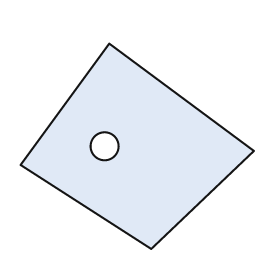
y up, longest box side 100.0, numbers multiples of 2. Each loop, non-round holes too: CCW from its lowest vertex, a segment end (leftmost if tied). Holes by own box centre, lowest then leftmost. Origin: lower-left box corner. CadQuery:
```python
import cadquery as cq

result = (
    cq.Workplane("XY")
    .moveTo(56.0, 0.0)
    .lineTo(100.0, 42.0)
    .lineTo(38.0, 88.0)
    .lineTo(0.0, 36.0)
    .close()
    .moveTo(36.0, 44.0)
    .circle(6.0)
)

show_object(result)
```